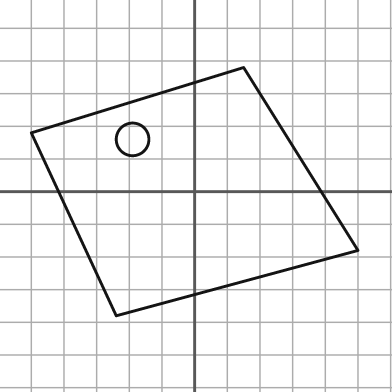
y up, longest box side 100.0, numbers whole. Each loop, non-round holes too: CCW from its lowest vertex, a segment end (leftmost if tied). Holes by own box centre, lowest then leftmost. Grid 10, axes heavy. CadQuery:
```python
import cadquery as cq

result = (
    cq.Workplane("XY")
    .moveTo(-24.0, -38.0)
    .lineTo(50.0, -18.0)
    .lineTo(15.0, 38.0)
    .lineTo(-50.0, 18.0)
    .close()
    .moveTo(-19.0, 16.0)
    .circle(5.0)
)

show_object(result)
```